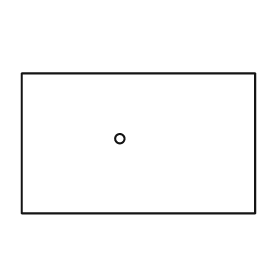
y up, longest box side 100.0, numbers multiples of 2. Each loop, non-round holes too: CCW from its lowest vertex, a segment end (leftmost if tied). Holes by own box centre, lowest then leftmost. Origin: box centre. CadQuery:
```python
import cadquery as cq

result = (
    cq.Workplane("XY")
    .moveTo(-50.0, -30.0)
    .lineTo(50.0, -30.0)
    .lineTo(50.0, 30.0)
    .lineTo(-50.0, 30.0)
    .close()
    .moveTo(-8.0, 2.0)
    .circle(2.0)
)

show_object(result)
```